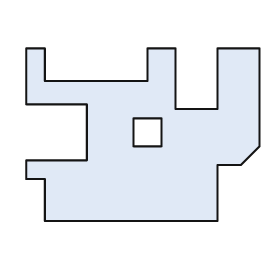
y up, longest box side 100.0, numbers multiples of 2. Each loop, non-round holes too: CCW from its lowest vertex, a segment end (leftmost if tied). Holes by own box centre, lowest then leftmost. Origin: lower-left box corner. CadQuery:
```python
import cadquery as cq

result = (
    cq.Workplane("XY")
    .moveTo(8.0, 0.0)
    .lineTo(82.0, 0.0)
    .lineTo(82.0, 24.0)
    .lineTo(92.0, 24.0)
    .lineTo(100.0, 32.0)
    .lineTo(100.0, 74.0)
    .lineTo(82.0, 74.0)
    .lineTo(82.0, 48.0)
    .lineTo(64.0, 48.0)
    .lineTo(64.0, 74.0)
    .lineTo(52.0, 74.0)
    .lineTo(52.0, 60.0)
    .lineTo(8.0, 60.0)
    .lineTo(8.0, 74.0)
    .lineTo(0.0, 74.0)
    .lineTo(0.0, 50.0)
    .lineTo(26.0, 50.0)
    .lineTo(26.0, 26.0)
    .lineTo(0.0, 26.0)
    .lineTo(0.0, 18.0)
    .lineTo(8.0, 18.0)
    .close()
    .moveTo(46.0, 32.0)
    .lineTo(58.0, 32.0)
    .lineTo(58.0, 44.0)
    .lineTo(46.0, 44.0)
    .close()
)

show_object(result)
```